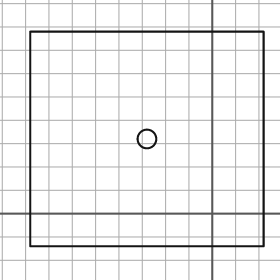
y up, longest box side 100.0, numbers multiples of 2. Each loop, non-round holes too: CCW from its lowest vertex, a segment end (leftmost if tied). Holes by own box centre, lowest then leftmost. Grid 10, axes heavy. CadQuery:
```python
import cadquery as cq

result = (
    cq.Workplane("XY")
    .moveTo(-78.0, -14.0)
    .lineTo(22.0, -14.0)
    .lineTo(22.0, 78.0)
    .lineTo(-78.0, 78.0)
    .close()
    .moveTo(-28.0, 32.0)
    .circle(4.0)
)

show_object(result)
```